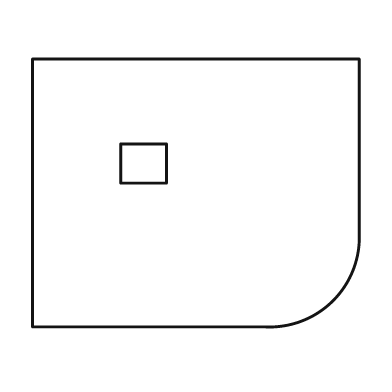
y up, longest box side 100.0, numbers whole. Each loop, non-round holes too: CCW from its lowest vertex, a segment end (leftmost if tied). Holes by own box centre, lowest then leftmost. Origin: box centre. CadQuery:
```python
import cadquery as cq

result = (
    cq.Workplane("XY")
    .moveTo(-50.0, -41.0)
    .lineTo(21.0, -41.0)
    .threePointArc((42.0, -33.0), (50.0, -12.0))
    .lineTo(50.0, 41.0)
    .lineTo(-50.0, 41.0)
    .close()
    .moveTo(-23.0, 3.0)
    .lineTo(-9.0, 3.0)
    .lineTo(-9.0, 15.0)
    .lineTo(-23.0, 15.0)
    .close()
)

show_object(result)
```